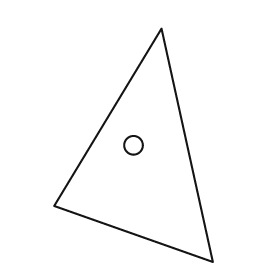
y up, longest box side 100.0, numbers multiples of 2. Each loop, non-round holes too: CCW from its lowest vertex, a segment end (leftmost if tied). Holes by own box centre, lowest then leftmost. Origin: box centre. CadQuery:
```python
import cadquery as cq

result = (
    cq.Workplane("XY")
    .moveTo(34.0, -50.0)
    .lineTo(12.0, 50.0)
    .lineTo(-34.0, -26.0)
    .close()
    .moveTo(0.0, 0.0)
    .circle(4.0)
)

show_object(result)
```